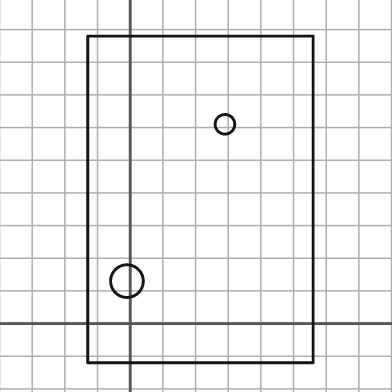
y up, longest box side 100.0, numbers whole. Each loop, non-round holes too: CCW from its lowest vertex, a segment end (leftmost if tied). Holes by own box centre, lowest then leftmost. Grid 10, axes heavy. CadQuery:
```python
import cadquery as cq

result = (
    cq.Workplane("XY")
    .moveTo(-13.0, -12.0)
    .lineTo(56.0, -12.0)
    .lineTo(56.0, 88.0)
    .lineTo(-13.0, 88.0)
    .close()
    .moveTo(-1.0, 13.0)
    .circle(5.0)
    .moveTo(29.0, 61.0)
    .circle(3.0)
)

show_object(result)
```